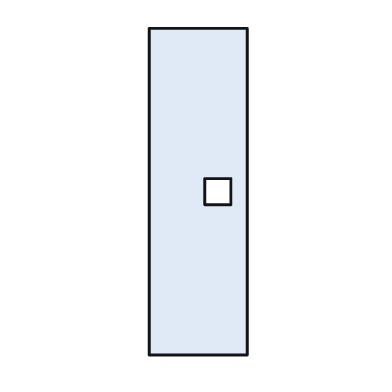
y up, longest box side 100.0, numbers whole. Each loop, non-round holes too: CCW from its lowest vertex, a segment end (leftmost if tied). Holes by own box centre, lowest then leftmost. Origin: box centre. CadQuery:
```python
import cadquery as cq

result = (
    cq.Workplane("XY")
    .moveTo(-15.0, -50.0)
    .lineTo(15.0, -50.0)
    .lineTo(15.0, 50.0)
    .lineTo(-15.0, 50.0)
    .close()
    .moveTo(2.0, -4.0)
    .lineTo(10.0, -4.0)
    .lineTo(10.0, 4.0)
    .lineTo(2.0, 4.0)
    .close()
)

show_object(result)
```